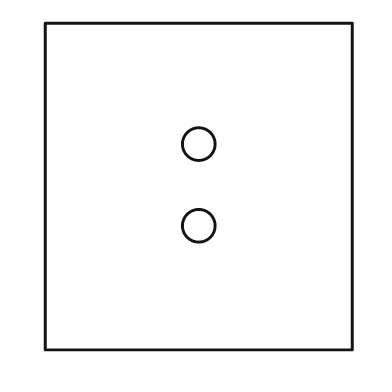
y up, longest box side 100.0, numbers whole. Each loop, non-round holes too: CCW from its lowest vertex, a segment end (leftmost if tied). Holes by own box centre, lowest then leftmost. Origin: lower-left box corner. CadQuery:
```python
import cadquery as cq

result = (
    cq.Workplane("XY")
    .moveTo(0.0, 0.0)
    .lineTo(94.0, 0.0)
    .lineTo(94.0, 100.0)
    .lineTo(0.0, 100.0)
    .close()
    .moveTo(47.0, 38.0)
    .circle(5.0)
    .moveTo(47.0, 63.0)
    .circle(5.0)
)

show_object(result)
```